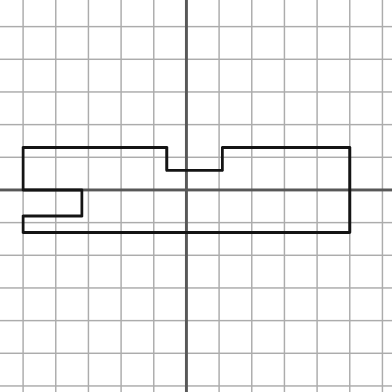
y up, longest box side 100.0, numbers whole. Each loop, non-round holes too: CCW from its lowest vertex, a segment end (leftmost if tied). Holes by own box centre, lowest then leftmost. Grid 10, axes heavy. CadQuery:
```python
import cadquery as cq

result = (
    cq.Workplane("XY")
    .moveTo(-50.0, -13.0)
    .lineTo(50.0, -13.0)
    .lineTo(50.0, 13.0)
    .lineTo(11.0, 13.0)
    .lineTo(11.0, 6.0)
    .lineTo(-6.0, 6.0)
    .lineTo(-6.0, 13.0)
    .lineTo(-50.0, 13.0)
    .lineTo(-50.0, 0.0)
    .lineTo(-32.0, 0.0)
    .lineTo(-32.0, -8.0)
    .lineTo(-50.0, -8.0)
    .close()
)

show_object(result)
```